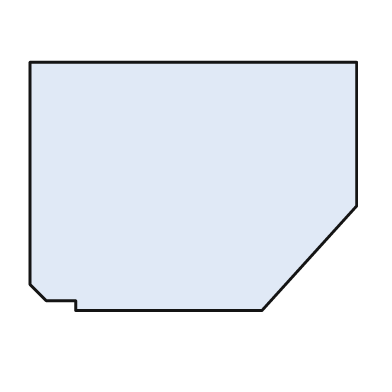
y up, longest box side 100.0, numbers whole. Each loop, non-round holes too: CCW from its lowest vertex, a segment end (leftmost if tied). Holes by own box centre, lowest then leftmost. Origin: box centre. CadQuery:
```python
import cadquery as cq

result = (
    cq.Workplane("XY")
    .moveTo(-36.0, -38.0)
    .lineTo(21.0, -38.0)
    .lineTo(50.0, -6.0)
    .lineTo(50.0, 38.0)
    .lineTo(-50.0, 38.0)
    .lineTo(-50.0, -30.0)
    .lineTo(-45.0, -35.0)
    .lineTo(-36.0, -35.0)
    .close()
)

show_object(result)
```